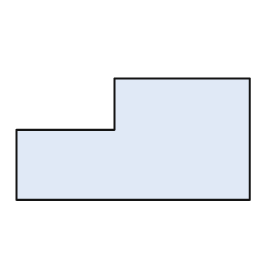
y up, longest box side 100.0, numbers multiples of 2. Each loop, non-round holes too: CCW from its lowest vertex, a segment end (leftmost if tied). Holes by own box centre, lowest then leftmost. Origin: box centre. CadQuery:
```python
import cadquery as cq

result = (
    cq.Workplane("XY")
    .moveTo(-50.0, -26.0)
    .lineTo(50.0, -26.0)
    .lineTo(50.0, 26.0)
    .lineTo(-8.0, 26.0)
    .lineTo(-8.0, 4.0)
    .lineTo(-50.0, 4.0)
    .close()
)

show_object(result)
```